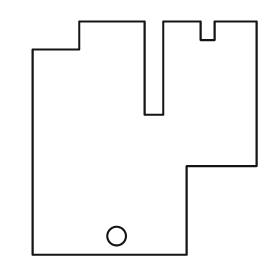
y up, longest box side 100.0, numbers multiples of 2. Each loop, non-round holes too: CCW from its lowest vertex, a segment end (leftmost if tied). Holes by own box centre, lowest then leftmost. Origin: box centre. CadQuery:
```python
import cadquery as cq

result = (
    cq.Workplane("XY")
    .moveTo(-48.0, -50.0)
    .lineTo(18.0, -50.0)
    .lineTo(18.0, -12.0)
    .lineTo(48.0, -12.0)
    .lineTo(48.0, 50.0)
    .lineTo(30.0, 50.0)
    .lineTo(30.0, 42.0)
    .lineTo(24.0, 42.0)
    .lineTo(24.0, 50.0)
    .lineTo(8.0, 50.0)
    .lineTo(8.0, 10.0)
    .lineTo(0.0, 10.0)
    .lineTo(0.0, 50.0)
    .lineTo(-28.0, 50.0)
    .lineTo(-28.0, 38.0)
    .lineTo(-48.0, 38.0)
    .close()
    .moveTo(-12.0, -42.0)
    .circle(4.0)
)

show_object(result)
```